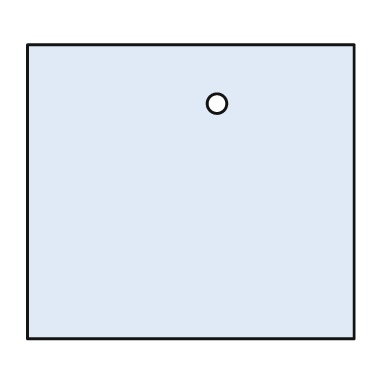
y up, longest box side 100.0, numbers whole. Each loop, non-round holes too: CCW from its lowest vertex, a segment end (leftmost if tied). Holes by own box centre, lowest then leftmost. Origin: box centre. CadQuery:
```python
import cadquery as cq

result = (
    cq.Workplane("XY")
    .moveTo(-50.0, -45.0)
    .lineTo(50.0, -45.0)
    .lineTo(50.0, 45.0)
    .lineTo(-50.0, 45.0)
    .close()
    .moveTo(8.0, 27.0)
    .circle(3.0)
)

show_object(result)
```